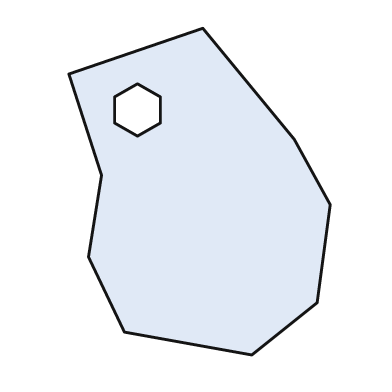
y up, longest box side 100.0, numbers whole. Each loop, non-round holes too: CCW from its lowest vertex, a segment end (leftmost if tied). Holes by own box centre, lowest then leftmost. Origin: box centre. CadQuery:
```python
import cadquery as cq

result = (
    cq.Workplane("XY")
    .moveTo(16.0, -50.0)
    .lineTo(36.0, -34.0)
    .lineTo(40.0, -4.0)
    .lineTo(29.0, 16.0)
    .lineTo(1.0, 50.0)
    .lineTo(-40.0, 36.0)
    .lineTo(-30.0, 5.0)
    .lineTo(-34.0, -20.0)
    .lineTo(-23.0, -43.0)
    .close()
    .moveTo(-19.0, 17.0)
    .lineTo(-12.0, 21.0)
    .lineTo(-12.0, 29.0)
    .lineTo(-19.0, 33.0)
    .lineTo(-26.0, 29.0)
    .lineTo(-26.0, 21.0)
    .close()
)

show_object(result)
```